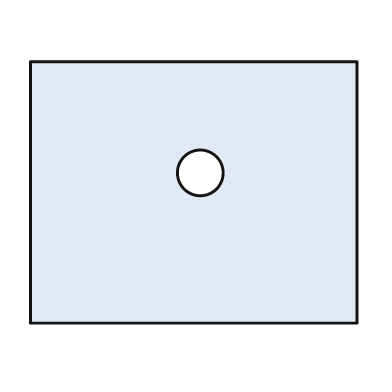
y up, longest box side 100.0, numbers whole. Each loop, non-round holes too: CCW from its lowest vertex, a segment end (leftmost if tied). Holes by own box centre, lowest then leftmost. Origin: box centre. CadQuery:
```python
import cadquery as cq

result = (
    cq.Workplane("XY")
    .moveTo(-50.0, -40.0)
    .lineTo(50.0, -40.0)
    .lineTo(50.0, 40.0)
    .lineTo(-50.0, 40.0)
    .close()
    .moveTo(2.0, 6.0)
    .circle(7.0)
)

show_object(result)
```